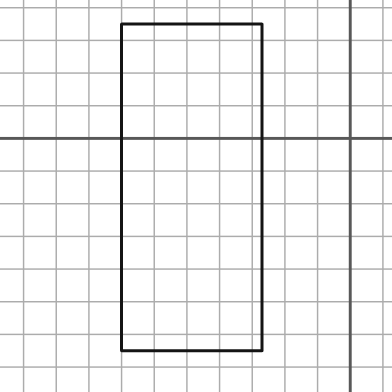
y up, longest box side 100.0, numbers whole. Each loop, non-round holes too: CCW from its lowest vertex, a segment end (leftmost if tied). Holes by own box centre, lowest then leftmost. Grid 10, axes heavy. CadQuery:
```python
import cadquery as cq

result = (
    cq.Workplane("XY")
    .moveTo(-70.0, -65.0)
    .lineTo(-27.0, -65.0)
    .lineTo(-27.0, 35.0)
    .lineTo(-70.0, 35.0)
    .close()
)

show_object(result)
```